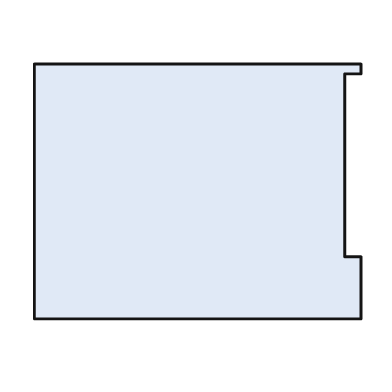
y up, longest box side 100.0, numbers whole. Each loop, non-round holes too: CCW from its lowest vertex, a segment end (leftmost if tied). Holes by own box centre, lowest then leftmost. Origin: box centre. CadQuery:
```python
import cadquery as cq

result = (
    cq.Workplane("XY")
    .moveTo(-50.0, -39.0)
    .lineTo(50.0, -39.0)
    .lineTo(50.0, -20.0)
    .lineTo(45.0, -20.0)
    .lineTo(45.0, 36.0)
    .lineTo(50.0, 36.0)
    .lineTo(50.0, 39.0)
    .lineTo(-50.0, 39.0)
    .close()
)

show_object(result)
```